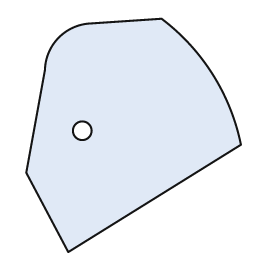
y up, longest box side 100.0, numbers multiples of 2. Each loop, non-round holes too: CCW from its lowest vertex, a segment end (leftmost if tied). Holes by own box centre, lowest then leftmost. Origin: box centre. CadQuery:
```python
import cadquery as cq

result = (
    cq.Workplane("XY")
    .moveTo(-28.0, -50.0)
    .lineTo(46.0, -4.0)
    .threePointArc((34.0, 26.0), (12.0, 50.0))
    .lineTo(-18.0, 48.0)
    .threePointArc((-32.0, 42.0), (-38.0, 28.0))
    .lineTo(-46.0, -16.0)
    .close()
    .moveTo(-22.0, 2.0)
    .circle(4.0)
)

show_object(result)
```